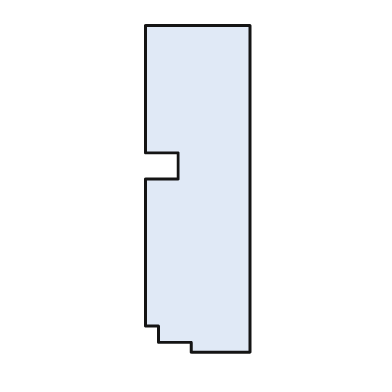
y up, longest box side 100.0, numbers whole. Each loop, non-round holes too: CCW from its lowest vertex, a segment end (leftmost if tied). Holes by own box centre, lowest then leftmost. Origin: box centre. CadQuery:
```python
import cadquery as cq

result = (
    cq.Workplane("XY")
    .moveTo(-2.0, -50.0)
    .lineTo(16.0, -50.0)
    .lineTo(16.0, 50.0)
    .lineTo(-16.0, 50.0)
    .lineTo(-16.0, 11.0)
    .lineTo(-6.0, 11.0)
    .lineTo(-6.0, 3.0)
    .lineTo(-16.0, 3.0)
    .lineTo(-16.0, -42.0)
    .lineTo(-12.0, -42.0)
    .lineTo(-12.0, -47.0)
    .lineTo(-2.0, -47.0)
    .close()
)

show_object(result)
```